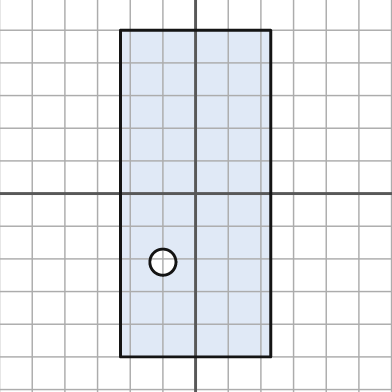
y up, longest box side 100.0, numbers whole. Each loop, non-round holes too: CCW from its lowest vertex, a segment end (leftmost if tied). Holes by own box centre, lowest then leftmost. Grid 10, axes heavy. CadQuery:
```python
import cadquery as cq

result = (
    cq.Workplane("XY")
    .moveTo(-23.0, -50.0)
    .lineTo(23.0, -50.0)
    .lineTo(23.0, 50.0)
    .lineTo(-23.0, 50.0)
    .close()
    .moveTo(-10.0, -21.0)
    .circle(4.0)
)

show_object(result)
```